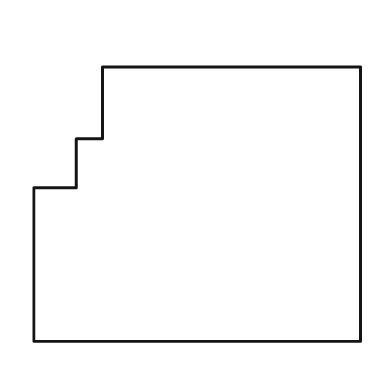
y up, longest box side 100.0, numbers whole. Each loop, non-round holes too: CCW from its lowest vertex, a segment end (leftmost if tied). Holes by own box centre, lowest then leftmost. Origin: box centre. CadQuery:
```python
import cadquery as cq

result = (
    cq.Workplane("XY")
    .moveTo(-50.0, -42.0)
    .lineTo(50.0, -42.0)
    .lineTo(50.0, 42.0)
    .lineTo(-29.0, 42.0)
    .lineTo(-29.0, 20.0)
    .lineTo(-37.0, 20.0)
    .lineTo(-37.0, 5.0)
    .lineTo(-50.0, 5.0)
    .close()
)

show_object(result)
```